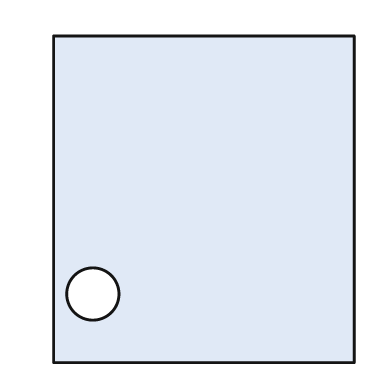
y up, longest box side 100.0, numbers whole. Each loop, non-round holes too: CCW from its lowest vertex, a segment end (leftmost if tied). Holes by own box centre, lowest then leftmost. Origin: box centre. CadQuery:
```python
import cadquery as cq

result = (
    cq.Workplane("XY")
    .moveTo(-46.0, -50.0)
    .lineTo(46.0, -50.0)
    .lineTo(46.0, 50.0)
    .lineTo(-46.0, 50.0)
    .close()
    .moveTo(-34.0, -29.0)
    .circle(8.0)
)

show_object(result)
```